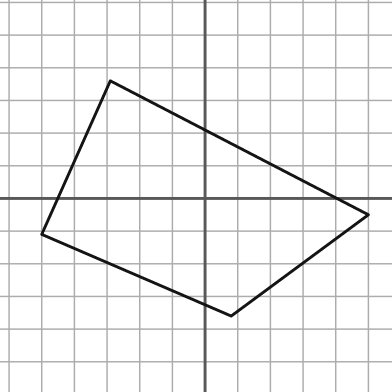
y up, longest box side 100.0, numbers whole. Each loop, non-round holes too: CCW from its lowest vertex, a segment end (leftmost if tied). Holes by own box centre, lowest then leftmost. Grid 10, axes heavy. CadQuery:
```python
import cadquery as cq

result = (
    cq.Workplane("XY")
    .moveTo(8.0, -36.0)
    .lineTo(50.0, -5.0)
    .lineTo(-29.0, 36.0)
    .lineTo(-50.0, -11.0)
    .close()
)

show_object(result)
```